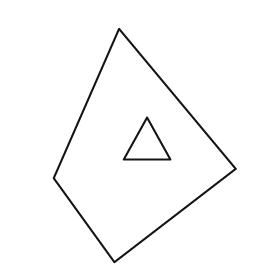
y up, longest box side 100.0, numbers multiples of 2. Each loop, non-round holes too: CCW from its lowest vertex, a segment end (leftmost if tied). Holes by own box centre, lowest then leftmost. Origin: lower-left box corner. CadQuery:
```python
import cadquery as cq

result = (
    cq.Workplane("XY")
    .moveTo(26.0, 0.0)
    .lineTo(78.0, 40.0)
    .lineTo(28.0, 100.0)
    .lineTo(0.0, 36.0)
    .close()
    .moveTo(30.0, 44.0)
    .lineTo(50.0, 44.0)
    .lineTo(40.0, 62.0)
    .close()
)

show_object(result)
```